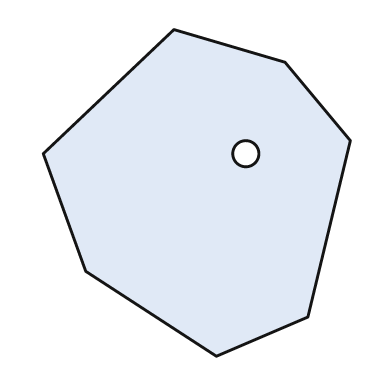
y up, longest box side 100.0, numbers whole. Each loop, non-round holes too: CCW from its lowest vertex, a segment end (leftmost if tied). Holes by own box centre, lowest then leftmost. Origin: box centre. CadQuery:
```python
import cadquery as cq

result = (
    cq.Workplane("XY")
    .moveTo(6.0, -50.0)
    .lineTo(34.0, -38.0)
    .lineTo(47.0, 16.0)
    .lineTo(27.0, 40.0)
    .lineTo(-7.0, 50.0)
    .lineTo(-47.0, 12.0)
    .lineTo(-34.0, -24.0)
    .close()
    .moveTo(15.0, 12.0)
    .circle(4.0)
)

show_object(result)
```